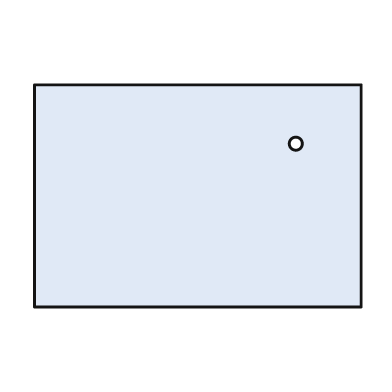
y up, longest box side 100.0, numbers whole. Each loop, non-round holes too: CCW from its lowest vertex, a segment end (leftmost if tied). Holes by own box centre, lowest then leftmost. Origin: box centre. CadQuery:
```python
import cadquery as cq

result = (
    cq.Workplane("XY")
    .moveTo(-50.0, -34.0)
    .lineTo(50.0, -34.0)
    .lineTo(50.0, 34.0)
    .lineTo(-50.0, 34.0)
    .close()
    .moveTo(30.0, 16.0)
    .circle(2.0)
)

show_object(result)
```